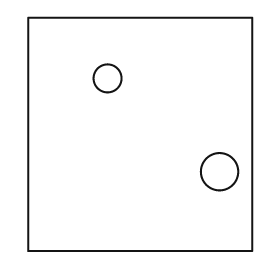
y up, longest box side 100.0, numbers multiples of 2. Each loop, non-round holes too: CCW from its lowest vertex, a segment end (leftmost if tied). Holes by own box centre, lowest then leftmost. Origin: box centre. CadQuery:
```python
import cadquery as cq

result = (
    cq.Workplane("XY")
    .moveTo(-48.0, -50.0)
    .lineTo(48.0, -50.0)
    .lineTo(48.0, 50.0)
    .lineTo(-48.0, 50.0)
    .close()
    .moveTo(34.0, -16.0)
    .circle(8.0)
    .moveTo(-14.0, 24.0)
    .circle(6.0)
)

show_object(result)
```